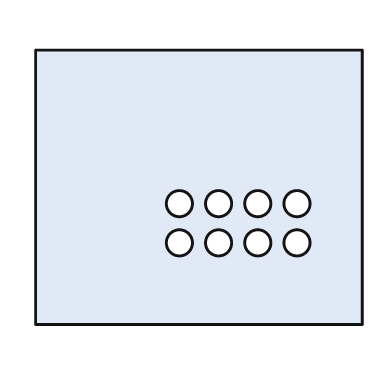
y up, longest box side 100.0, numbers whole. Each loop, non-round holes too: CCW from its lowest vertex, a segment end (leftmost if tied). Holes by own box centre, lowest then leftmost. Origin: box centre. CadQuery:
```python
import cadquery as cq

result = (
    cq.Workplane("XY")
    .moveTo(-50.0, -42.0)
    .lineTo(50.0, -42.0)
    .lineTo(50.0, 42.0)
    .lineTo(-50.0, 42.0)
    .close()
    .moveTo(-6.0, -17.0)
    .circle(4.0)
    .moveTo(6.0, -17.0)
    .circle(4.0)
    .moveTo(18.0, -17.0)
    .circle(4.0)
    .moveTo(30.0, -17.0)
    .circle(4.0)
    .moveTo(-6.0, -5.0)
    .circle(4.0)
    .moveTo(6.0, -5.0)
    .circle(4.0)
    .moveTo(18.0, -5.0)
    .circle(4.0)
    .moveTo(30.0, -5.0)
    .circle(4.0)
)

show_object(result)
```